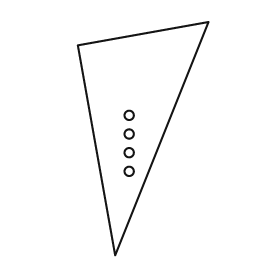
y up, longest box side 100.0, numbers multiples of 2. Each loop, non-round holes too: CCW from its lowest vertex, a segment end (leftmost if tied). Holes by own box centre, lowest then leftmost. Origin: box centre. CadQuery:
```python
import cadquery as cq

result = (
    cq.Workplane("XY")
    .moveTo(-12.0, -50.0)
    .lineTo(28.0, 50.0)
    .lineTo(-28.0, 40.0)
    .close()
    .moveTo(-6.0, -14.0)
    .circle(2.0)
    .moveTo(-6.0, -6.0)
    .circle(2.0)
    .moveTo(-6.0, 2.0)
    .circle(2.0)
    .moveTo(-6.0, 10.0)
    .circle(2.0)
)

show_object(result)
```